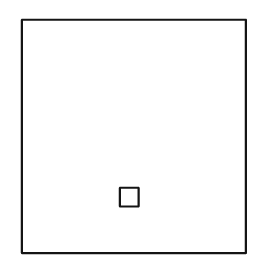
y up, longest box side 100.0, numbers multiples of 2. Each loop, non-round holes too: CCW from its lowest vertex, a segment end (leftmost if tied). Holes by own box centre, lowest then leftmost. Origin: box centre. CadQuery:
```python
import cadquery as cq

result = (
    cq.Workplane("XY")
    .moveTo(-48.0, -50.0)
    .lineTo(48.0, -50.0)
    .lineTo(48.0, 50.0)
    .lineTo(-48.0, 50.0)
    .close()
    .moveTo(-6.0, -30.0)
    .lineTo(2.0, -30.0)
    .lineTo(2.0, -22.0)
    .lineTo(-6.0, -22.0)
    .close()
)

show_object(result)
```